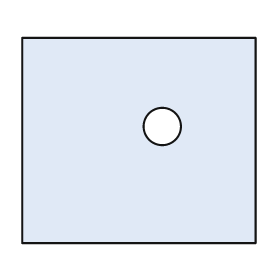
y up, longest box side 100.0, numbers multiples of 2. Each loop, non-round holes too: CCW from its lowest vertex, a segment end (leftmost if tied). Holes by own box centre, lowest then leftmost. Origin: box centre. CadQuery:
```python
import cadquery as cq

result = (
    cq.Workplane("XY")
    .moveTo(-50.0, -44.0)
    .lineTo(50.0, -44.0)
    .lineTo(50.0, 44.0)
    .lineTo(-50.0, 44.0)
    .close()
    .moveTo(10.0, 6.0)
    .circle(8.0)
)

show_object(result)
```